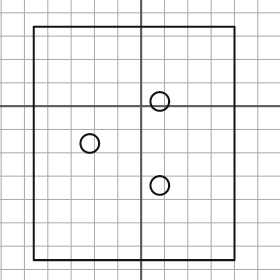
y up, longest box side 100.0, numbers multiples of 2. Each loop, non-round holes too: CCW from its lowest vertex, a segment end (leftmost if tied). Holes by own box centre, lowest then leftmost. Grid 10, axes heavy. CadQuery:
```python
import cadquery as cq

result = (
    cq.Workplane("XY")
    .moveTo(-46.0, -66.0)
    .lineTo(40.0, -66.0)
    .lineTo(40.0, 34.0)
    .lineTo(-46.0, 34.0)
    .close()
    .moveTo(8.0, -34.0)
    .circle(4.0)
    .moveTo(-22.0, -16.0)
    .circle(4.0)
    .moveTo(8.0, 2.0)
    .circle(4.0)
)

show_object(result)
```